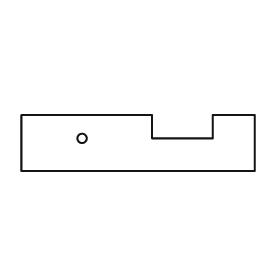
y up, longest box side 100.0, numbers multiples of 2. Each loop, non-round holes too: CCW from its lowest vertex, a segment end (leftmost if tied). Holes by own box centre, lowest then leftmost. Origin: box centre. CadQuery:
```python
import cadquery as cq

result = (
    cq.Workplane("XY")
    .moveTo(-50.0, -12.0)
    .lineTo(50.0, -12.0)
    .lineTo(50.0, 12.0)
    .lineTo(32.0, 12.0)
    .lineTo(32.0, 2.0)
    .lineTo(6.0, 2.0)
    .lineTo(6.0, 12.0)
    .lineTo(-50.0, 12.0)
    .close()
    .moveTo(-24.0, 2.0)
    .circle(2.0)
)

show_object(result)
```